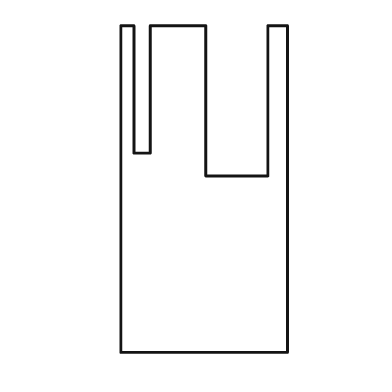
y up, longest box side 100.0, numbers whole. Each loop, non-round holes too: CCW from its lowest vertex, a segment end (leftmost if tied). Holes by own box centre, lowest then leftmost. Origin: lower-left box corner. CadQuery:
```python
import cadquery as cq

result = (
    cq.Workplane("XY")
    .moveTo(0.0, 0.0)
    .lineTo(51.0, 0.0)
    .lineTo(51.0, 100.0)
    .lineTo(45.0, 100.0)
    .lineTo(45.0, 54.0)
    .lineTo(26.0, 54.0)
    .lineTo(26.0, 100.0)
    .lineTo(9.0, 100.0)
    .lineTo(9.0, 61.0)
    .lineTo(4.0, 61.0)
    .lineTo(4.0, 100.0)
    .lineTo(0.0, 100.0)
    .close()
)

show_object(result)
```